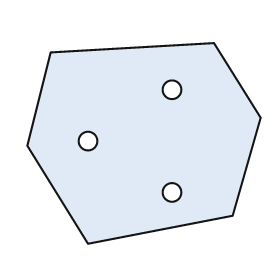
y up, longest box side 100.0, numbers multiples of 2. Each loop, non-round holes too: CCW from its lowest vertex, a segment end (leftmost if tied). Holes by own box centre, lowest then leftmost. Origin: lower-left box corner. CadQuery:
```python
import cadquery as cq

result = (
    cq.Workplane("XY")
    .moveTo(26.0, 0.0)
    .lineTo(88.0, 12.0)
    .lineTo(100.0, 54.0)
    .lineTo(80.0, 86.0)
    .lineTo(10.0, 82.0)
    .lineTo(0.0, 42.0)
    .close()
    .moveTo(62.0, 22.0)
    .circle(4.0)
    .moveTo(26.0, 44.0)
    .circle(4.0)
    .moveTo(62.0, 66.0)
    .circle(4.0)
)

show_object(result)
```